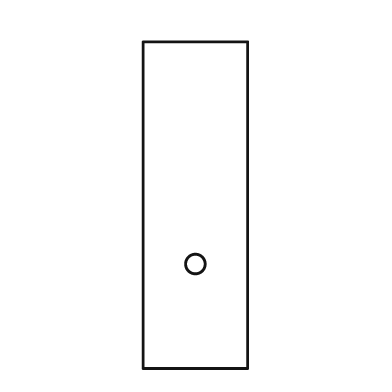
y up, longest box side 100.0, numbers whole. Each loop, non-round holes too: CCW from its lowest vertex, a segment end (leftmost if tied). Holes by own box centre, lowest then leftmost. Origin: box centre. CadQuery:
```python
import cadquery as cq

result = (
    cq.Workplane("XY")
    .moveTo(-16.0, -50.0)
    .lineTo(16.0, -50.0)
    .lineTo(16.0, 50.0)
    .lineTo(-16.0, 50.0)
    .close()
    .moveTo(0.0, -18.0)
    .circle(3.0)
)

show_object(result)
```